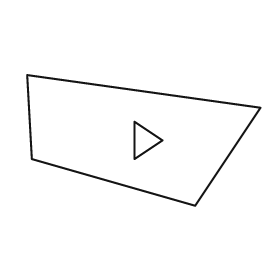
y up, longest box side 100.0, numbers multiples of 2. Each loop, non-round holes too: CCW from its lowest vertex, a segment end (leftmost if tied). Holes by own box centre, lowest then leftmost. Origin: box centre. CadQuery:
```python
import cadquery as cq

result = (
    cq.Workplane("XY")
    .moveTo(22.0, -28.0)
    .lineTo(50.0, 14.0)
    .lineTo(-50.0, 28.0)
    .lineTo(-48.0, -8.0)
    .close()
    .moveTo(-4.0, -8.0)
    .lineTo(8.0, 0.0)
    .lineTo(-4.0, 8.0)
    .close()
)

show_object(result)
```